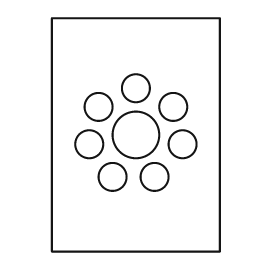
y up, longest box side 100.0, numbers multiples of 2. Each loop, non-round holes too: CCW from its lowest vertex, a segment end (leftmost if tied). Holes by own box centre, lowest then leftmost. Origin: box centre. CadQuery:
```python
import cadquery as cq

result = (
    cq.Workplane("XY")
    .moveTo(-36.0, -50.0)
    .lineTo(36.0, -50.0)
    .lineTo(36.0, 50.0)
    .lineTo(-36.0, 50.0)
    .close()
    .moveTo(-10.0, -18.0)
    .circle(6.0)
    .moveTo(8.0, -18.0)
    .circle(6.0)
    .moveTo(-20.0, -4.0)
    .circle(6.0)
    .moveTo(20.0, -4.0)
    .circle(6.0)
    .moveTo(0.0, 0.0)
    .circle(10.0)
    .moveTo(-16.0, 12.0)
    .circle(6.0)
    .moveTo(16.0, 12.0)
    .circle(6.0)
    .moveTo(0.0, 20.0)
    .circle(6.0)
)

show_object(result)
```